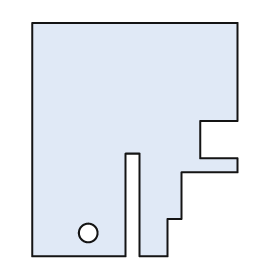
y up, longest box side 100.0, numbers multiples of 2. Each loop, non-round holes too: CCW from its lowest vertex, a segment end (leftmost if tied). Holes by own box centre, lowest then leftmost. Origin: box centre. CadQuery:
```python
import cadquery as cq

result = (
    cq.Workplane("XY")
    .moveTo(-44.0, -50.0)
    .lineTo(-4.0, -50.0)
    .lineTo(-4.0, -6.0)
    .lineTo(2.0, -6.0)
    .lineTo(2.0, -50.0)
    .lineTo(14.0, -50.0)
    .lineTo(14.0, -34.0)
    .lineTo(20.0, -34.0)
    .lineTo(20.0, -14.0)
    .lineTo(44.0, -14.0)
    .lineTo(44.0, -8.0)
    .lineTo(28.0, -8.0)
    .lineTo(28.0, 8.0)
    .lineTo(44.0, 8.0)
    .lineTo(44.0, 50.0)
    .lineTo(-44.0, 50.0)
    .close()
    .moveTo(-20.0, -40.0)
    .circle(4.0)
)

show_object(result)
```